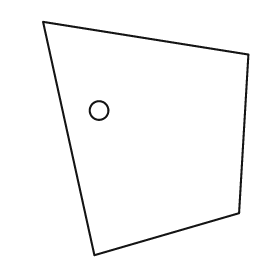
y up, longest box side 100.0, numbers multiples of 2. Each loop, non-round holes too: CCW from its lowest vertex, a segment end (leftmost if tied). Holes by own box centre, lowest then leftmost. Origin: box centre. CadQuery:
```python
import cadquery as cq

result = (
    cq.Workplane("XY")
    .moveTo(-22.0, -50.0)
    .lineTo(40.0, -32.0)
    .lineTo(44.0, 36.0)
    .lineTo(-44.0, 50.0)
    .close()
    .moveTo(-20.0, 12.0)
    .circle(4.0)
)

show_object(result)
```